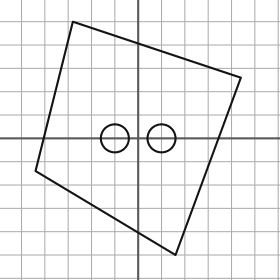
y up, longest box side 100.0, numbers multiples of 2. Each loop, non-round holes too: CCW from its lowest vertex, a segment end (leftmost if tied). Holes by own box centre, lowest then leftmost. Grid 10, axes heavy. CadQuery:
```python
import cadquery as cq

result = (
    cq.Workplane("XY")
    .moveTo(16.0, -50.0)
    .lineTo(44.0, 26.0)
    .lineTo(-28.0, 50.0)
    .lineTo(-44.0, -14.0)
    .close()
    .moveTo(-10.0, 0.0)
    .circle(6.0)
    .moveTo(10.0, 0.0)
    .circle(6.0)
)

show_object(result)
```